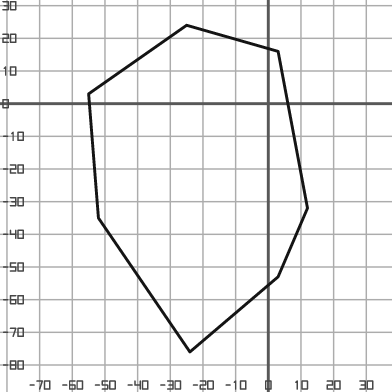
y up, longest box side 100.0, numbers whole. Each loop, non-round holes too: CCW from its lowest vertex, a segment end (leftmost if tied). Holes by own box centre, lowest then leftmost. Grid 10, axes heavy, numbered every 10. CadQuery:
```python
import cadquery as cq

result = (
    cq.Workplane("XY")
    .moveTo(-24.0, -76.0)
    .lineTo(3.0, -53.0)
    .lineTo(12.0, -32.0)
    .lineTo(3.0, 16.0)
    .lineTo(-25.0, 24.0)
    .lineTo(-55.0, 3.0)
    .lineTo(-52.0, -35.0)
    .close()
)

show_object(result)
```